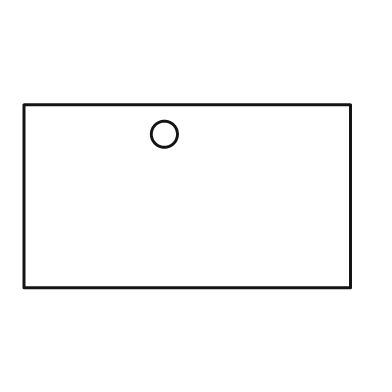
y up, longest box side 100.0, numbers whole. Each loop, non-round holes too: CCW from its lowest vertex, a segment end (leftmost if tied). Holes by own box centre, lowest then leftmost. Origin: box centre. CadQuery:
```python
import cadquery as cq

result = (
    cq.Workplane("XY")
    .moveTo(-50.0, -28.0)
    .lineTo(50.0, -28.0)
    .lineTo(50.0, 28.0)
    .lineTo(-50.0, 28.0)
    .close()
    .moveTo(-7.0, 19.0)
    .circle(4.0)
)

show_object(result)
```